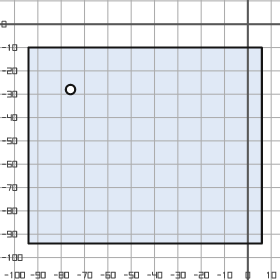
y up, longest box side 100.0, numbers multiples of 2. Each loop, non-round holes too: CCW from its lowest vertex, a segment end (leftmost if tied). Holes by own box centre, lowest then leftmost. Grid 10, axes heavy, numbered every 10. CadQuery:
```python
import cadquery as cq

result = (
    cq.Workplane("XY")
    .moveTo(-94.0, -94.0)
    .lineTo(6.0, -94.0)
    .lineTo(6.0, -10.0)
    .lineTo(-94.0, -10.0)
    .close()
    .moveTo(-76.0, -28.0)
    .circle(2.0)
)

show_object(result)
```